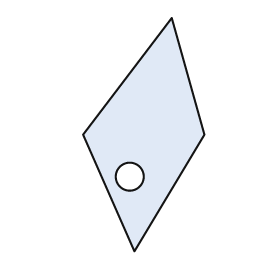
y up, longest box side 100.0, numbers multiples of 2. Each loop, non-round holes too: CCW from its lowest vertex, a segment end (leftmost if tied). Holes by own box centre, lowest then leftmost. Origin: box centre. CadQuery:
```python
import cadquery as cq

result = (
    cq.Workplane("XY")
    .moveTo(-4.0, -50.0)
    .lineTo(26.0, 0.0)
    .lineTo(12.0, 50.0)
    .lineTo(-26.0, 0.0)
    .close()
    .moveTo(-6.0, -18.0)
    .circle(6.0)
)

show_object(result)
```